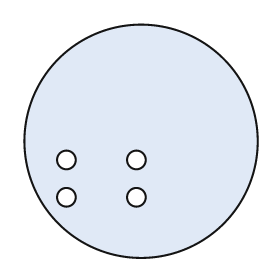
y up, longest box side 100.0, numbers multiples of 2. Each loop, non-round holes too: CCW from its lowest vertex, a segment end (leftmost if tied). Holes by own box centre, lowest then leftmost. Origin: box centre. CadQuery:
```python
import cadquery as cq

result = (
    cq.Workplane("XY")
    .moveTo(0.0, 0.0)
    .circle(50.0)
    .moveTo(-32.0, -24.0)
    .circle(4.0)
    .moveTo(-2.0, -24.0)
    .circle(4.0)
    .moveTo(-32.0, -8.0)
    .circle(4.0)
    .moveTo(-2.0, -8.0)
    .circle(4.0)
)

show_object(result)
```